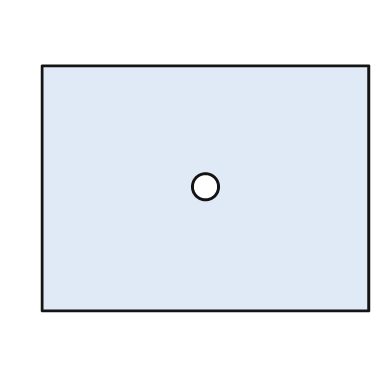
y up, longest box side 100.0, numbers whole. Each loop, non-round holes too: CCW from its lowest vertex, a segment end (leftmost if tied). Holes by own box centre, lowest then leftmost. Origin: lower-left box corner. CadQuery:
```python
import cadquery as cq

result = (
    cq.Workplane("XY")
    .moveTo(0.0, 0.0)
    .lineTo(100.0, 0.0)
    .lineTo(100.0, 75.0)
    .lineTo(0.0, 75.0)
    .close()
    .moveTo(50.0, 38.0)
    .circle(4.0)
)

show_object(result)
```